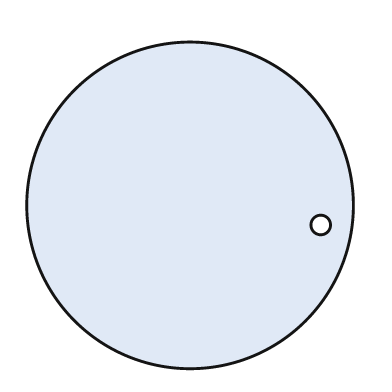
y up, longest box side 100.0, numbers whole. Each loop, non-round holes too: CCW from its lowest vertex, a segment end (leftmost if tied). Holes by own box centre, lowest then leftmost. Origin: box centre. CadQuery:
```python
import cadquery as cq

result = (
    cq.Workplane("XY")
    .moveTo(0.0, 0.0)
    .circle(50.0)
    .moveTo(40.0, -6.0)
    .circle(3.0)
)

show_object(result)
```